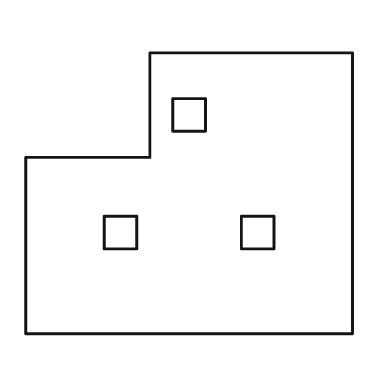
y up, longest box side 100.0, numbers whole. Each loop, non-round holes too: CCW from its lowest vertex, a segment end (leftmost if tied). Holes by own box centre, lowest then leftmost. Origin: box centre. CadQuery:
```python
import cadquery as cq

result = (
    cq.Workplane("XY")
    .moveTo(-50.0, -43.0)
    .lineTo(50.0, -43.0)
    .lineTo(50.0, 43.0)
    .lineTo(-12.0, 43.0)
    .lineTo(-12.0, 11.0)
    .lineTo(-50.0, 11.0)
    .close()
    .moveTo(-26.0, -17.0)
    .lineTo(-16.0, -17.0)
    .lineTo(-16.0, -7.0)
    .lineTo(-26.0, -7.0)
    .close()
    .moveTo(16.0, -17.0)
    .lineTo(26.0, -17.0)
    .lineTo(26.0, -7.0)
    .lineTo(16.0, -7.0)
    .close()
    .moveTo(-5.0, 19.0)
    .lineTo(5.0, 19.0)
    .lineTo(5.0, 29.0)
    .lineTo(-5.0, 29.0)
    .close()
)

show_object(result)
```